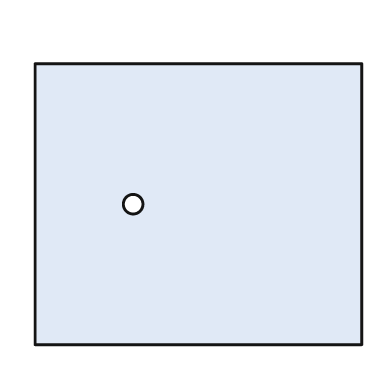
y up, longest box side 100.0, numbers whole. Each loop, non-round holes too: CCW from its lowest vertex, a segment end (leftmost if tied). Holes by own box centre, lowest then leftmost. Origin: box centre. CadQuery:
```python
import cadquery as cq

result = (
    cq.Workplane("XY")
    .moveTo(-50.0, -43.0)
    .lineTo(50.0, -43.0)
    .lineTo(50.0, 43.0)
    .lineTo(-50.0, 43.0)
    .close()
    .moveTo(-20.0, 0.0)
    .circle(3.0)
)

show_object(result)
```